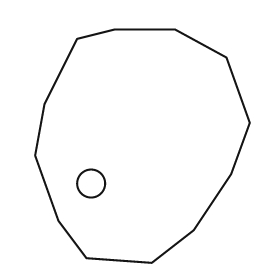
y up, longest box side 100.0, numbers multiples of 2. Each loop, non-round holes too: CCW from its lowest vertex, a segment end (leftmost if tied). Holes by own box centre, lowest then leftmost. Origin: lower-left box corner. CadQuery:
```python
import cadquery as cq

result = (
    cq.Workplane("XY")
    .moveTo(50.0, 0.0)
    .lineTo(68.0, 14.0)
    .lineTo(84.0, 38.0)
    .lineTo(92.0, 60.0)
    .lineTo(82.0, 88.0)
    .lineTo(60.0, 100.0)
    .lineTo(34.0, 100.0)
    .lineTo(18.0, 96.0)
    .lineTo(4.0, 68.0)
    .lineTo(0.0, 46.0)
    .lineTo(10.0, 18.0)
    .lineTo(22.0, 2.0)
    .close()
    .moveTo(24.0, 34.0)
    .circle(6.0)
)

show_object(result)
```